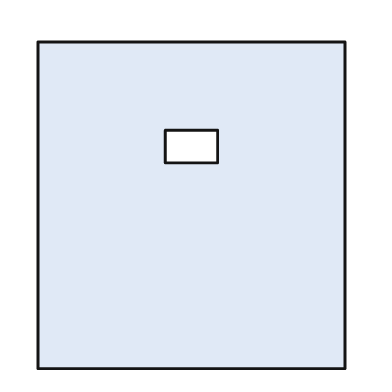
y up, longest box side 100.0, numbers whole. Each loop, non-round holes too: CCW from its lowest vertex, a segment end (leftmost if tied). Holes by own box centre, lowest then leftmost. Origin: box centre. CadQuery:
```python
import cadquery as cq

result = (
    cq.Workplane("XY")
    .moveTo(-47.0, -50.0)
    .lineTo(47.0, -50.0)
    .lineTo(47.0, 50.0)
    .lineTo(-47.0, 50.0)
    .close()
    .moveTo(-8.0, 13.0)
    .lineTo(8.0, 13.0)
    .lineTo(8.0, 23.0)
    .lineTo(-8.0, 23.0)
    .close()
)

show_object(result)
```